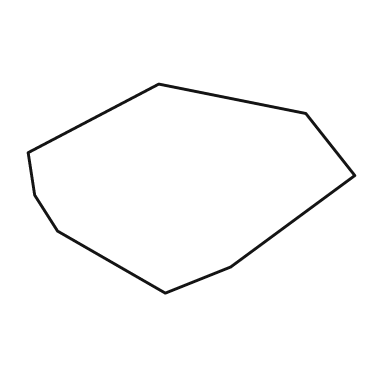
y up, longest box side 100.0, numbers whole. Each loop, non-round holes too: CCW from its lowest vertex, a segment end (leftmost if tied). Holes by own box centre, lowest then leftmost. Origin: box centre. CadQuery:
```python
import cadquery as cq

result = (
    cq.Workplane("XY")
    .moveTo(-8.0, -32.0)
    .lineTo(12.0, -24.0)
    .lineTo(50.0, 4.0)
    .lineTo(35.0, 23.0)
    .lineTo(-10.0, 32.0)
    .lineTo(-50.0, 11.0)
    .lineTo(-48.0, -2.0)
    .lineTo(-41.0, -13.0)
    .close()
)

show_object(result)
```